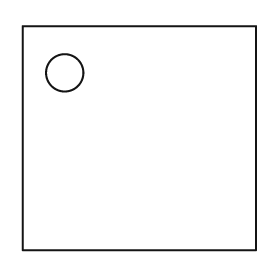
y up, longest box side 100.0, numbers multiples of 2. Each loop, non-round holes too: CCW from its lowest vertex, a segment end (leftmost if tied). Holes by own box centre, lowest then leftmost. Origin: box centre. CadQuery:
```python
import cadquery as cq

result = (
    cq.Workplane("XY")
    .moveTo(-50.0, -48.0)
    .lineTo(50.0, -48.0)
    .lineTo(50.0, 48.0)
    .lineTo(-50.0, 48.0)
    .close()
    .moveTo(-32.0, 28.0)
    .circle(8.0)
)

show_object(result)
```